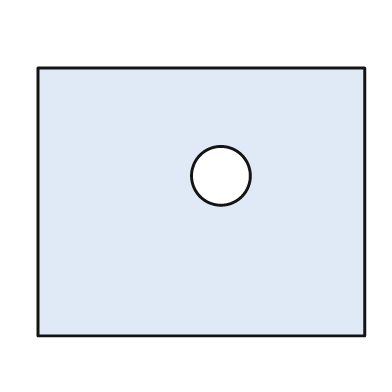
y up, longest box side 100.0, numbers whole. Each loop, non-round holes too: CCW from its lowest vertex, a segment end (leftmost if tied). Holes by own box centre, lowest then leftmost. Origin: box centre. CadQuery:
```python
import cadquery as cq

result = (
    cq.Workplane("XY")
    .moveTo(-50.0, -41.0)
    .lineTo(50.0, -41.0)
    .lineTo(50.0, 41.0)
    .lineTo(-50.0, 41.0)
    .close()
    .moveTo(6.0, 8.0)
    .circle(9.0)
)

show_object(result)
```